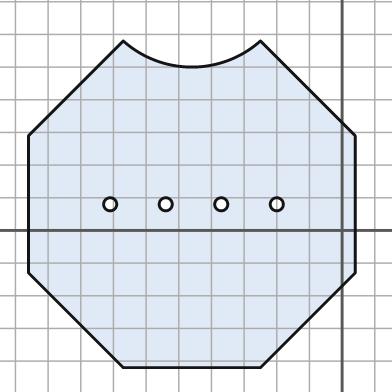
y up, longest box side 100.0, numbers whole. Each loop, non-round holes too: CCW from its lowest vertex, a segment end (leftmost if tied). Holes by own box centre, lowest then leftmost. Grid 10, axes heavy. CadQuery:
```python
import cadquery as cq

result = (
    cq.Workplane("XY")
    .moveTo(-67.0, -42.0)
    .lineTo(-25.0, -42.0)
    .lineTo(4.0, -13.0)
    .lineTo(4.0, 29.0)
    .lineTo(-25.0, 58.0)
    .threePointArc((-46.0, 50.0), (-67.0, 58.0))
    .lineTo(-96.0, 29.0)
    .lineTo(-96.0, -13.0)
    .close()
    .moveTo(-71.0, 8.0)
    .circle(2.0)
    .moveTo(-54.0, 8.0)
    .circle(2.0)
    .moveTo(-37.0, 8.0)
    .circle(2.0)
    .moveTo(-20.0, 8.0)
    .circle(2.0)
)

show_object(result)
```